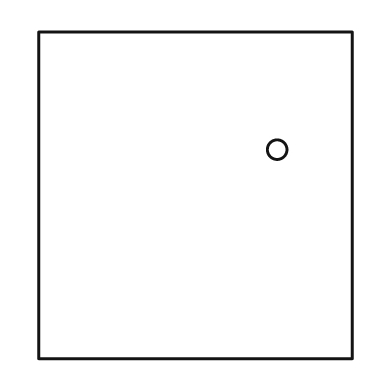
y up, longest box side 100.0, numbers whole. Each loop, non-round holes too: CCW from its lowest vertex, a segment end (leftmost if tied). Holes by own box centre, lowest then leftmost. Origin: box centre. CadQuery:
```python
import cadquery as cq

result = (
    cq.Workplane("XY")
    .moveTo(-48.0, -50.0)
    .lineTo(48.0, -50.0)
    .lineTo(48.0, 50.0)
    .lineTo(-48.0, 50.0)
    .close()
    .moveTo(25.0, 14.0)
    .circle(3.0)
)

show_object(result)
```